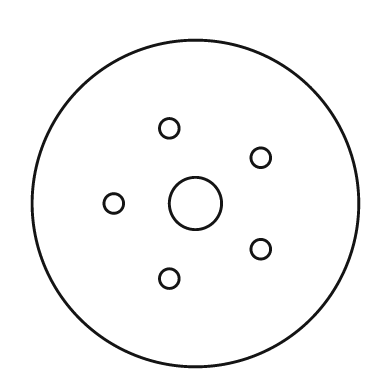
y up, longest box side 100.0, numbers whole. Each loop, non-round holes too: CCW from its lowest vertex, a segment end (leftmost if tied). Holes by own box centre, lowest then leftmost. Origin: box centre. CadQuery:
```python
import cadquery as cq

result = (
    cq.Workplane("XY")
    .moveTo(0.0, 0.0)
    .circle(50.0)
    .moveTo(-8.0, -23.0)
    .circle(3.0)
    .moveTo(20.0, -14.0)
    .circle(3.0)
    .moveTo(-25.0, 0.0)
    .circle(3.0)
    .moveTo(0.0, 0.0)
    .circle(8.0)
    .moveTo(20.0, 14.0)
    .circle(3.0)
    .moveTo(-8.0, 23.0)
    .circle(3.0)
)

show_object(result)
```